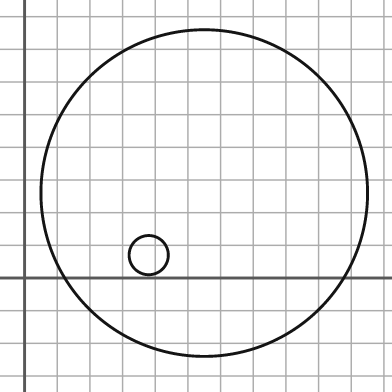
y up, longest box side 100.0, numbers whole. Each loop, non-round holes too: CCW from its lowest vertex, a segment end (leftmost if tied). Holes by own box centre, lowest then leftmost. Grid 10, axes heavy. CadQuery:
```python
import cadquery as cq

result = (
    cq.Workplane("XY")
    .moveTo(55.0, 26.0)
    .circle(50.0)
    .moveTo(38.0, 7.0)
    .circle(6.0)
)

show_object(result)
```